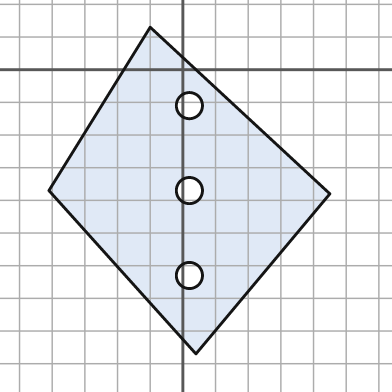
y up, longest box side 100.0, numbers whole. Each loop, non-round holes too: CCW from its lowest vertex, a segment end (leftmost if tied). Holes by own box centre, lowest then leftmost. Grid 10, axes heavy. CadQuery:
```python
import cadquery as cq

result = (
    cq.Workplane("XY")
    .moveTo(4.0, -87.0)
    .lineTo(45.0, -38.0)
    .lineTo(-10.0, 13.0)
    .lineTo(-41.0, -37.0)
    .close()
    .moveTo(2.0, -63.0)
    .circle(4.0)
    .moveTo(2.0, -37.0)
    .circle(4.0)
    .moveTo(2.0, -11.0)
    .circle(4.0)
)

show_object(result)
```